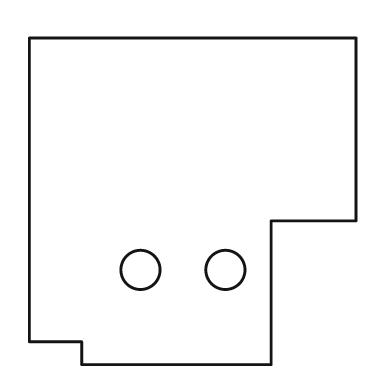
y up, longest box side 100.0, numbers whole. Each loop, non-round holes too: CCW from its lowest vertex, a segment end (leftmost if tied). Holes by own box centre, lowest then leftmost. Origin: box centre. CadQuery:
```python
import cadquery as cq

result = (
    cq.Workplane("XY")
    .moveTo(-34.0, -50.0)
    .lineTo(24.0, -50.0)
    .lineTo(24.0, -6.0)
    .lineTo(50.0, -6.0)
    .lineTo(50.0, 50.0)
    .lineTo(-50.0, 50.0)
    .lineTo(-50.0, -43.0)
    .lineTo(-34.0, -43.0)
    .close()
    .moveTo(-16.0, -21.0)
    .circle(6.0)
    .moveTo(10.0, -21.0)
    .circle(6.0)
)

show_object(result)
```